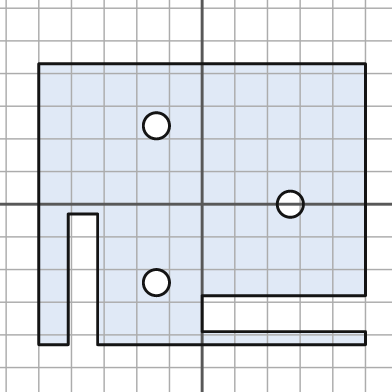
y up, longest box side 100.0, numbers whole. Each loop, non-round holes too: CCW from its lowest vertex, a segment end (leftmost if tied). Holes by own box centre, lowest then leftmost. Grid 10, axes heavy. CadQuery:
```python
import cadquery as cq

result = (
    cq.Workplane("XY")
    .moveTo(-50.0, -43.0)
    .lineTo(-41.0, -43.0)
    .lineTo(-41.0, -3.0)
    .lineTo(-32.0, -3.0)
    .lineTo(-32.0, -43.0)
    .lineTo(50.0, -43.0)
    .lineTo(50.0, -39.0)
    .lineTo(0.0, -39.0)
    .lineTo(0.0, -28.0)
    .lineTo(50.0, -28.0)
    .lineTo(50.0, 43.0)
    .lineTo(-50.0, 43.0)
    .close()
    .moveTo(-14.0, -24.0)
    .circle(4.0)
    .moveTo(27.0, 0.0)
    .circle(4.0)
    .moveTo(-14.0, 24.0)
    .circle(4.0)
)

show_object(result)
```